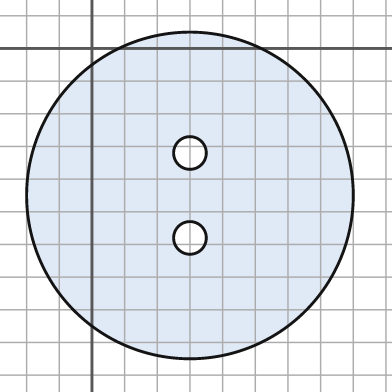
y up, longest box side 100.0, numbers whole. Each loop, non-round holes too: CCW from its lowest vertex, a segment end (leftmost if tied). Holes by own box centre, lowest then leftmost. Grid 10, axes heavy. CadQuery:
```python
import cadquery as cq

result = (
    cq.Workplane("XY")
    .moveTo(30.0, -45.0)
    .circle(50.0)
    .moveTo(30.0, -58.0)
    .circle(5.0)
    .moveTo(30.0, -32.0)
    .circle(5.0)
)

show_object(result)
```